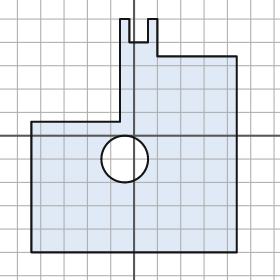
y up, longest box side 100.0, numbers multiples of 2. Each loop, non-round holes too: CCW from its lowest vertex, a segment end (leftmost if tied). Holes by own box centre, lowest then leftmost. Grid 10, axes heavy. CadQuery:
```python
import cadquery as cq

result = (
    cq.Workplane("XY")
    .moveTo(-44.0, -50.0)
    .lineTo(44.0, -50.0)
    .lineTo(44.0, 34.0)
    .lineTo(10.0, 34.0)
    .lineTo(10.0, 50.0)
    .lineTo(6.0, 50.0)
    .lineTo(6.0, 40.0)
    .lineTo(-2.0, 40.0)
    .lineTo(-2.0, 50.0)
    .lineTo(-6.0, 50.0)
    .lineTo(-6.0, 6.0)
    .lineTo(-44.0, 6.0)
    .close()
    .moveTo(-4.0, -10.0)
    .circle(10.0)
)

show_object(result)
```